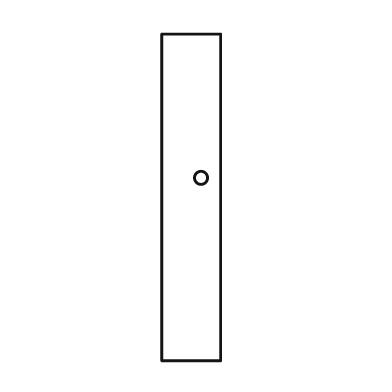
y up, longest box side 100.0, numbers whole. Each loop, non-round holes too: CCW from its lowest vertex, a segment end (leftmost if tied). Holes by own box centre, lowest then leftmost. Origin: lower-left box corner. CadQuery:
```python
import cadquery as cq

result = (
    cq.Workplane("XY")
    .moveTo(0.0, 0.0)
    .lineTo(18.0, 0.0)
    .lineTo(18.0, 100.0)
    .lineTo(0.0, 100.0)
    .close()
    .moveTo(12.0, 56.0)
    .circle(2.0)
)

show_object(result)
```